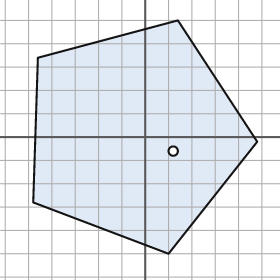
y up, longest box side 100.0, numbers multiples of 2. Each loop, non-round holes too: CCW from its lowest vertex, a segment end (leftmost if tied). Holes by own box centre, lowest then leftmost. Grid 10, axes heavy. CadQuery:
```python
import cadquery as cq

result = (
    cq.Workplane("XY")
    .moveTo(10.0, -50.0)
    .lineTo(48.0, -2.0)
    .lineTo(14.0, 50.0)
    .lineTo(-46.0, 34.0)
    .lineTo(-48.0, -28.0)
    .close()
    .moveTo(12.0, -6.0)
    .circle(2.0)
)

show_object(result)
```